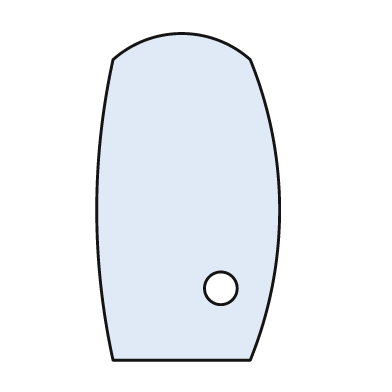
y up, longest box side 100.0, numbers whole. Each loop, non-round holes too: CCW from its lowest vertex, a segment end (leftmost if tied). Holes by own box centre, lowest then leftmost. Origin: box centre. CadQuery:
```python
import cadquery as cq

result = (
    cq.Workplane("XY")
    .moveTo(-23.0, -50.0)
    .lineTo(19.0, -50.0)
    .threePointArc((28.0, -4.0), (19.0, 42.0))
    .threePointArc((-2.0, 50.0), (-23.0, 42.0))
    .threePointArc((-28.0, -4.0), (-23.0, -50.0))
    .close()
    .moveTo(10.0, -28.0)
    .circle(5.0)
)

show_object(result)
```